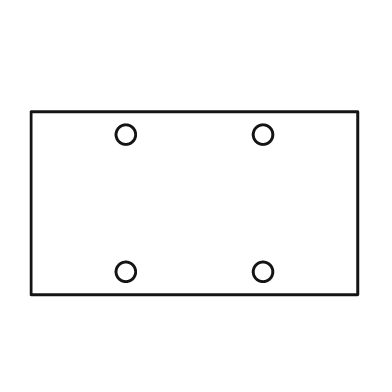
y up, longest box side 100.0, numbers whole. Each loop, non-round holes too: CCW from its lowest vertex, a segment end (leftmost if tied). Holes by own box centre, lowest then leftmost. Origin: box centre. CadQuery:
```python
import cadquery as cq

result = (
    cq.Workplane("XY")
    .moveTo(-50.0, -28.0)
    .lineTo(50.0, -28.0)
    .lineTo(50.0, 28.0)
    .lineTo(-50.0, 28.0)
    .close()
    .moveTo(-21.0, -21.0)
    .circle(3.0)
    .moveTo(21.0, -21.0)
    .circle(3.0)
    .moveTo(-21.0, 21.0)
    .circle(3.0)
    .moveTo(21.0, 21.0)
    .circle(3.0)
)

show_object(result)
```